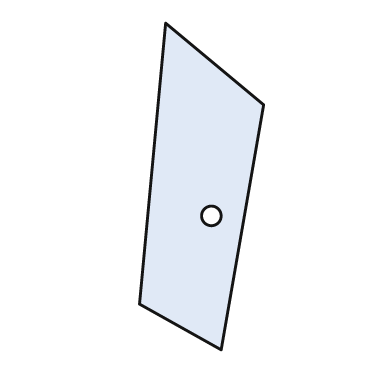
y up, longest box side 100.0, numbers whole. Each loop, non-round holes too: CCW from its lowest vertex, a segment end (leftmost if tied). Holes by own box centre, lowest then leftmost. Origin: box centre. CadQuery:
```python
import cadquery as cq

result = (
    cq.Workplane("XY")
    .moveTo(6.0, -50.0)
    .lineTo(19.0, 25.0)
    .lineTo(-11.0, 50.0)
    .lineTo(-19.0, -36.0)
    .close()
    .moveTo(3.0, -9.0)
    .circle(3.0)
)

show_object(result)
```